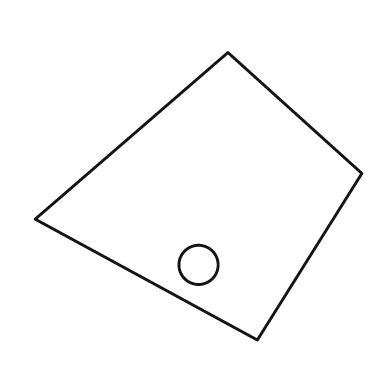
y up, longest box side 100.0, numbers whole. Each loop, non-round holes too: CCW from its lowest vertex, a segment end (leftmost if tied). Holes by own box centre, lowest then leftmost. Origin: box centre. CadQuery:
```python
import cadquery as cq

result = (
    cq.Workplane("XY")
    .moveTo(18.0, -44.0)
    .lineTo(50.0, 7.0)
    .lineTo(9.0, 44.0)
    .lineTo(-50.0, -7.0)
    .close()
    .moveTo(0.0, -21.0)
    .circle(6.0)
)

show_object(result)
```